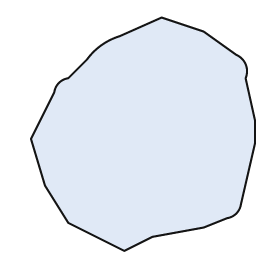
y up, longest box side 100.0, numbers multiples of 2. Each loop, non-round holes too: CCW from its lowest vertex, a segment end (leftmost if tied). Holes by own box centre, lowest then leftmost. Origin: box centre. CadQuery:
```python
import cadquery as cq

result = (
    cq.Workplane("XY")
    .moveTo(-8.0, -50.0)
    .lineTo(4.0, -44.0)
    .lineTo(26.0, -40.0)
    .lineTo(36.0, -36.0)
    .threePointArc((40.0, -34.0), (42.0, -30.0))
    .lineTo(48.0, -4.0)
    .lineTo(48.0, 6.0)
    .lineTo(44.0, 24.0)
    .threePointArc((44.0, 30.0), (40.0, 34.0))
    .lineTo(26.0, 44.0)
    .lineTo(8.0, 50.0)
    .lineTo(-10.0, 42.0)
    .threePointArc((-18.0, 38.0), (-24.0, 32.0))
    .lineTo(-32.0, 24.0)
    .threePointArc((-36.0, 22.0), (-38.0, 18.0))
    .lineTo(-48.0, -2.0)
    .lineTo(-42.0, -22.0)
    .lineTo(-32.0, -38.0)
    .close()
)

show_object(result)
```